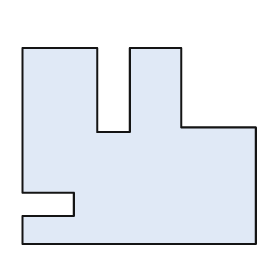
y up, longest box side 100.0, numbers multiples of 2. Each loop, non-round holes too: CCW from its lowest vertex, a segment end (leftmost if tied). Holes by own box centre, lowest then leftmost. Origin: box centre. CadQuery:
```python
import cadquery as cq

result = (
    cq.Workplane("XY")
    .moveTo(-50.0, -42.0)
    .lineTo(50.0, -42.0)
    .lineTo(50.0, 8.0)
    .lineTo(18.0, 8.0)
    .lineTo(18.0, 42.0)
    .lineTo(-4.0, 42.0)
    .lineTo(-4.0, 6.0)
    .lineTo(-18.0, 6.0)
    .lineTo(-18.0, 42.0)
    .lineTo(-50.0, 42.0)
    .lineTo(-50.0, -20.0)
    .lineTo(-28.0, -20.0)
    .lineTo(-28.0, -30.0)
    .lineTo(-50.0, -30.0)
    .close()
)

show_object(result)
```